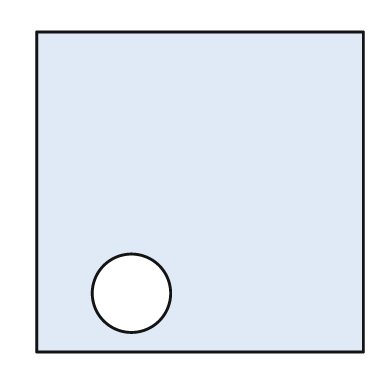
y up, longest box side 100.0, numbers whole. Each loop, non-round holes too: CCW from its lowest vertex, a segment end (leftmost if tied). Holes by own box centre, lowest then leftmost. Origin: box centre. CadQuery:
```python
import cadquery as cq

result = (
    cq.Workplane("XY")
    .moveTo(-50.0, -49.0)
    .lineTo(50.0, -49.0)
    .lineTo(50.0, 49.0)
    .lineTo(-50.0, 49.0)
    .close()
    .moveTo(-21.0, -31.0)
    .circle(12.0)
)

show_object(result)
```